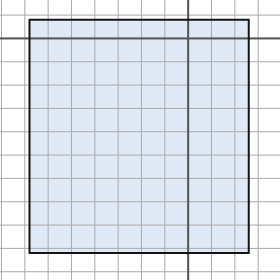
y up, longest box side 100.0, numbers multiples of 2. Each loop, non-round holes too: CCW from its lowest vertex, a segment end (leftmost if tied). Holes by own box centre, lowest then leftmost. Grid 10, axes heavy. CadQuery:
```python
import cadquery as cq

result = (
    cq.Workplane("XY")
    .moveTo(-68.0, -92.0)
    .lineTo(26.0, -92.0)
    .lineTo(26.0, 8.0)
    .lineTo(-68.0, 8.0)
    .close()
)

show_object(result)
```